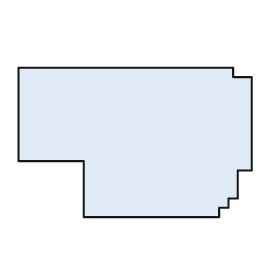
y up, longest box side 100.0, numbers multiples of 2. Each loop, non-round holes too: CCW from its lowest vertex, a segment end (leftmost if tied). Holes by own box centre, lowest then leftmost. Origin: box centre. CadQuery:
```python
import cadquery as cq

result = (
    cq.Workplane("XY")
    .moveTo(-22.0, -32.0)
    .lineTo(36.0, -32.0)
    .lineTo(36.0, -28.0)
    .lineTo(40.0, -28.0)
    .lineTo(40.0, -24.0)
    .lineTo(44.0, -24.0)
    .lineTo(44.0, -12.0)
    .lineTo(50.0, -12.0)
    .lineTo(50.0, 28.0)
    .lineTo(42.0, 28.0)
    .lineTo(42.0, 32.0)
    .lineTo(-50.0, 32.0)
    .lineTo(-50.0, -8.0)
    .lineTo(-22.0, -8.0)
    .close()
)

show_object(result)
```